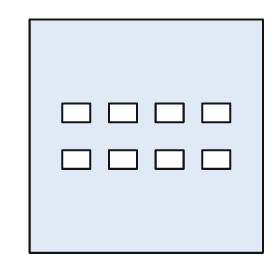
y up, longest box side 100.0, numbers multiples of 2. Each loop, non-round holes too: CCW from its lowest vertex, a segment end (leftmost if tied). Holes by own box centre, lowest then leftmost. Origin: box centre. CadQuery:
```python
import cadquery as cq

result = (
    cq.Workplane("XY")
    .moveTo(-50.0, -50.0)
    .lineTo(50.0, -50.0)
    .lineTo(50.0, 50.0)
    .lineTo(-50.0, 50.0)
    .close()
    .moveTo(-36.0, -14.0)
    .lineTo(-24.0, -14.0)
    .lineTo(-24.0, -6.0)
    .lineTo(-36.0, -6.0)
    .close()
    .moveTo(-16.0, -14.0)
    .lineTo(-4.0, -14.0)
    .lineTo(-4.0, -6.0)
    .lineTo(-16.0, -6.0)
    .close()
    .moveTo(4.0, -14.0)
    .lineTo(16.0, -14.0)
    .lineTo(16.0, -6.0)
    .lineTo(4.0, -6.0)
    .close()
    .moveTo(24.0, -14.0)
    .lineTo(36.0, -14.0)
    .lineTo(36.0, -6.0)
    .lineTo(24.0, -6.0)
    .close()
    .moveTo(-36.0, 6.0)
    .lineTo(-24.0, 6.0)
    .lineTo(-24.0, 14.0)
    .lineTo(-36.0, 14.0)
    .close()
    .moveTo(-16.0, 6.0)
    .lineTo(-4.0, 6.0)
    .lineTo(-4.0, 14.0)
    .lineTo(-16.0, 14.0)
    .close()
    .moveTo(4.0, 6.0)
    .lineTo(16.0, 6.0)
    .lineTo(16.0, 14.0)
    .lineTo(4.0, 14.0)
    .close()
    .moveTo(24.0, 6.0)
    .lineTo(36.0, 6.0)
    .lineTo(36.0, 14.0)
    .lineTo(24.0, 14.0)
    .close()
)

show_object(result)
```